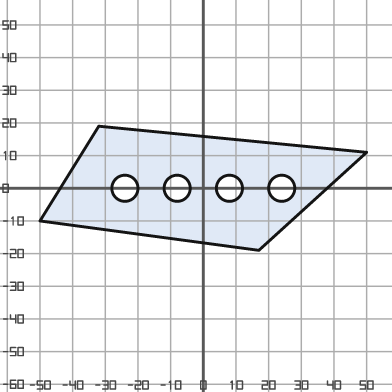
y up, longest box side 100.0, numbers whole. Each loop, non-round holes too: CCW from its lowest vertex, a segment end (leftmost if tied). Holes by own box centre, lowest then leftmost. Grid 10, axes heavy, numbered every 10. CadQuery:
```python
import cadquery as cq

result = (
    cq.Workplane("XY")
    .moveTo(17.0, -19.0)
    .lineTo(50.0, 11.0)
    .lineTo(-32.0, 19.0)
    .lineTo(-50.0, -10.0)
    .close()
    .moveTo(-24.0, 0.0)
    .circle(4.0)
    .moveTo(-8.0, 0.0)
    .circle(4.0)
    .moveTo(8.0, 0.0)
    .circle(4.0)
    .moveTo(24.0, 0.0)
    .circle(4.0)
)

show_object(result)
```